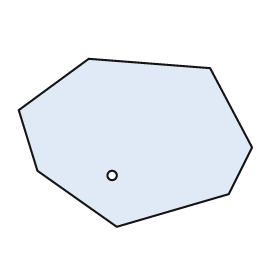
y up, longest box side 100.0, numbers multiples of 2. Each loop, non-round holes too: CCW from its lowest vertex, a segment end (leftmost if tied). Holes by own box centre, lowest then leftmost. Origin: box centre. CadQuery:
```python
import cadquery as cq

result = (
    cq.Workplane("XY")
    .moveTo(-8.0, -36.0)
    .lineTo(40.0, -22.0)
    .lineTo(50.0, -2.0)
    .lineTo(32.0, 32.0)
    .lineTo(-20.0, 36.0)
    .lineTo(-50.0, 14.0)
    .lineTo(-42.0, -12.0)
    .close()
    .moveTo(-10.0, -14.0)
    .circle(2.0)
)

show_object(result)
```